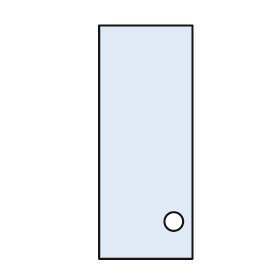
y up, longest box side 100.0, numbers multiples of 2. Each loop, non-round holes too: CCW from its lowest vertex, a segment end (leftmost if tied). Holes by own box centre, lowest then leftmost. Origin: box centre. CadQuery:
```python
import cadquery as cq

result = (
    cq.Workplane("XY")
    .moveTo(-20.0, -50.0)
    .lineTo(20.0, -50.0)
    .lineTo(20.0, 50.0)
    .lineTo(-20.0, 50.0)
    .close()
    .moveTo(12.0, -34.0)
    .circle(4.0)
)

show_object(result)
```